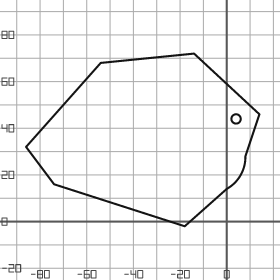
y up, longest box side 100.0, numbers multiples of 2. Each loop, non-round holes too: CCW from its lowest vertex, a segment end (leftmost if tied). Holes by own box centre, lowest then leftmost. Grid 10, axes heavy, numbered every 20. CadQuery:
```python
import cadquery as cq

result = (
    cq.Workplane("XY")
    .moveTo(-18.0, -2.0)
    .lineTo(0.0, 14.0)
    .threePointArc((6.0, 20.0), (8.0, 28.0))
    .lineTo(14.0, 46.0)
    .lineTo(-14.0, 72.0)
    .lineTo(-54.0, 68.0)
    .lineTo(-86.0, 32.0)
    .lineTo(-74.0, 16.0)
    .close()
    .moveTo(4.0, 44.0)
    .circle(2.0)
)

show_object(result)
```